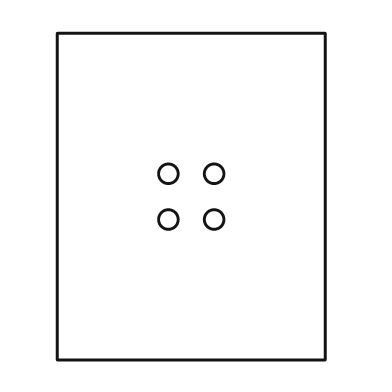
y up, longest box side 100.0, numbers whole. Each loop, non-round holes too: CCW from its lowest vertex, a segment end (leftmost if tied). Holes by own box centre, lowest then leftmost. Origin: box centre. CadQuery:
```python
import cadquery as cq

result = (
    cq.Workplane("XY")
    .moveTo(-41.0, -50.0)
    .lineTo(41.0, -50.0)
    .lineTo(41.0, 50.0)
    .lineTo(-41.0, 50.0)
    .close()
    .moveTo(-7.0, -7.0)
    .circle(3.0)
    .moveTo(7.0, -7.0)
    .circle(3.0)
    .moveTo(-7.0, 7.0)
    .circle(3.0)
    .moveTo(7.0, 7.0)
    .circle(3.0)
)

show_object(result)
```